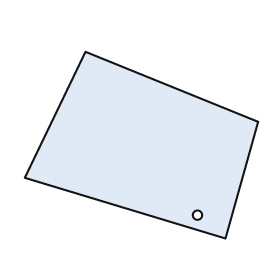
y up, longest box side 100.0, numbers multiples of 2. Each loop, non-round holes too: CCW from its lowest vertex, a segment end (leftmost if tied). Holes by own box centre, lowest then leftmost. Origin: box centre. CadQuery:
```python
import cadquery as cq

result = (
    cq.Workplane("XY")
    .moveTo(36.0, -40.0)
    .lineTo(50.0, 10.0)
    .lineTo(-24.0, 40.0)
    .lineTo(-50.0, -14.0)
    .close()
    .moveTo(24.0, -30.0)
    .circle(2.0)
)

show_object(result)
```